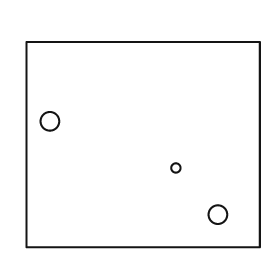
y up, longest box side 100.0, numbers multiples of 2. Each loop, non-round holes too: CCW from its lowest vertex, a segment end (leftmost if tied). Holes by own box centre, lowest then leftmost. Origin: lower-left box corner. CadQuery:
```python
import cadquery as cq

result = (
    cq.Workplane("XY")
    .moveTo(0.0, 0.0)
    .lineTo(100.0, 0.0)
    .lineTo(100.0, 88.0)
    .lineTo(0.0, 88.0)
    .close()
    .moveTo(82.0, 14.0)
    .circle(4.0)
    .moveTo(64.0, 34.0)
    .circle(2.0)
    .moveTo(10.0, 54.0)
    .circle(4.0)
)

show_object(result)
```